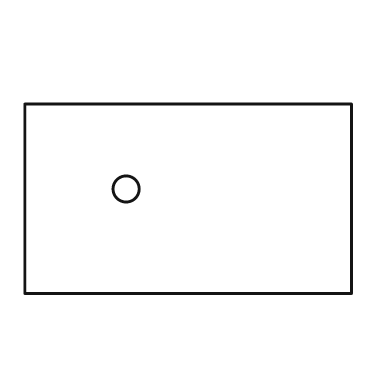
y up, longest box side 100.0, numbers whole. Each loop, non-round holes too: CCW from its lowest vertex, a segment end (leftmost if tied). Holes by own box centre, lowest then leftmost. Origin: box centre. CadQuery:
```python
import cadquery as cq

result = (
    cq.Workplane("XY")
    .moveTo(-50.0, -29.0)
    .lineTo(50.0, -29.0)
    .lineTo(50.0, 29.0)
    .lineTo(-50.0, 29.0)
    .close()
    .moveTo(-19.0, 3.0)
    .circle(4.0)
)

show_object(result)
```